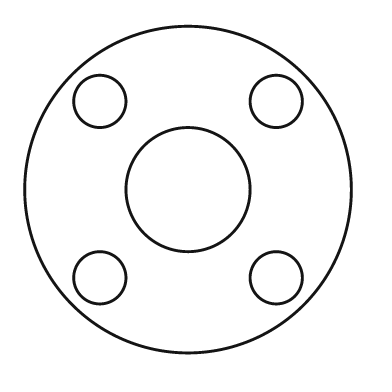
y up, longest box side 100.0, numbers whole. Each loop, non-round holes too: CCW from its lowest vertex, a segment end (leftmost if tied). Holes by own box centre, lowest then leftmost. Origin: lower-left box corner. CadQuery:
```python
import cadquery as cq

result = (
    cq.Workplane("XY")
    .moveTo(50.0, 50.0)
    .circle(50.0)
    .moveTo(23.0, 23.0)
    .circle(8.0)
    .moveTo(77.0, 23.0)
    .circle(8.0)
    .moveTo(50.0, 50.0)
    .circle(19.0)
    .moveTo(23.0, 77.0)
    .circle(8.0)
    .moveTo(77.0, 77.0)
    .circle(8.0)
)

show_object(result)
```